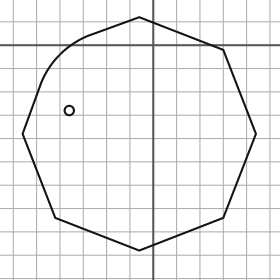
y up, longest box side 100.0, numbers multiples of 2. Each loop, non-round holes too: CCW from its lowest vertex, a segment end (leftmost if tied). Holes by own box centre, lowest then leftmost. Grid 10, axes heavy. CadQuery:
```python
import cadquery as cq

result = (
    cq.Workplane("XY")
    .moveTo(-6.0, -88.0)
    .lineTo(30.0, -74.0)
    .lineTo(44.0, -38.0)
    .lineTo(30.0, -2.0)
    .lineTo(-6.0, 12.0)
    .lineTo(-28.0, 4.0)
    .threePointArc((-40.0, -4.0), (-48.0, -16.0))
    .lineTo(-56.0, -38.0)
    .lineTo(-42.0, -74.0)
    .close()
    .moveTo(-36.0, -28.0)
    .circle(2.0)
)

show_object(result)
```